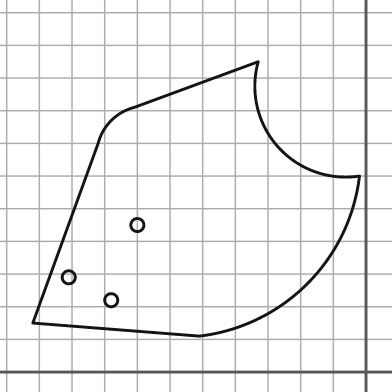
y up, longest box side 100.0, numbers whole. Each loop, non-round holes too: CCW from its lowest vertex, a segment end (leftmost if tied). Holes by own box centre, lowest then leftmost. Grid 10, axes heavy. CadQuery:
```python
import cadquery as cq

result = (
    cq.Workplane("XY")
    .moveTo(-51.0, 11.0)
    .threePointArc((-18.0, 27.0), (-2.0, 60.0))
    .threePointArc((-27.0, 69.0), (-33.0, 95.0))
    .lineTo(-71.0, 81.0)
    .threePointArc((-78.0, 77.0), (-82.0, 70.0))
    .lineTo(-102.0, 15.0)
    .close()
    .moveTo(-78.0, 22.0)
    .circle(2.0)
    .moveTo(-91.0, 29.0)
    .circle(2.0)
    .moveTo(-70.0, 45.0)
    .circle(2.0)
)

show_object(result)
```